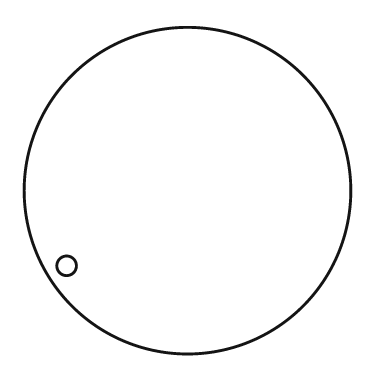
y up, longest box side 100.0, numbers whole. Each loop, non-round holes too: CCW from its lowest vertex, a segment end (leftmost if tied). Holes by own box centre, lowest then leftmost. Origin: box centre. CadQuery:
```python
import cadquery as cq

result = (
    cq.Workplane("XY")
    .moveTo(0.0, 0.0)
    .circle(50.0)
    .moveTo(-37.0, -23.0)
    .circle(3.0)
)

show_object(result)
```